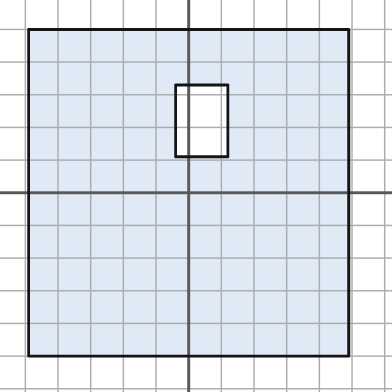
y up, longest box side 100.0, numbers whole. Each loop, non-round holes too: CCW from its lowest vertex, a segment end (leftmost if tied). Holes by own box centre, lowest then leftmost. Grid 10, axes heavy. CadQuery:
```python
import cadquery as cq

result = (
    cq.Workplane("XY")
    .moveTo(-49.0, -50.0)
    .lineTo(49.0, -50.0)
    .lineTo(49.0, 50.0)
    .lineTo(-49.0, 50.0)
    .close()
    .moveTo(-4.0, 11.0)
    .lineTo(12.0, 11.0)
    .lineTo(12.0, 33.0)
    .lineTo(-4.0, 33.0)
    .close()
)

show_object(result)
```